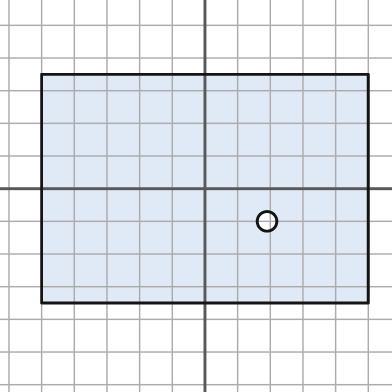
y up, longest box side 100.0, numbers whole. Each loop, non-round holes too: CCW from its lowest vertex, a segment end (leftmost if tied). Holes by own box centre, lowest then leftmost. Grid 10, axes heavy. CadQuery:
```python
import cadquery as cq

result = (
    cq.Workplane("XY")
    .moveTo(-50.0, -35.0)
    .lineTo(50.0, -35.0)
    .lineTo(50.0, 35.0)
    .lineTo(-50.0, 35.0)
    .close()
    .moveTo(19.0, -10.0)
    .circle(3.0)
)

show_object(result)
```